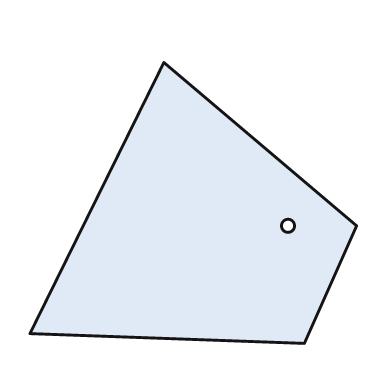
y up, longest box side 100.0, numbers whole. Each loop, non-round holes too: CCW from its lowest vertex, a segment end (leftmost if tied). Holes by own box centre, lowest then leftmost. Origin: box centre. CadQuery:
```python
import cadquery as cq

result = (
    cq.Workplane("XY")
    .moveTo(34.0, -43.0)
    .lineTo(50.0, -7.0)
    .lineTo(-9.0, 43.0)
    .lineTo(-50.0, -40.0)
    .close()
    .moveTo(29.0, -7.0)
    .circle(2.0)
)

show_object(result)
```